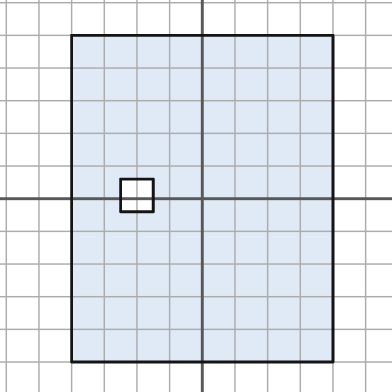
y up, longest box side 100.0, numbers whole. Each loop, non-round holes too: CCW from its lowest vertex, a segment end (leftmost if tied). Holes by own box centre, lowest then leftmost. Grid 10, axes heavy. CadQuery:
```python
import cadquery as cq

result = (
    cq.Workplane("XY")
    .moveTo(-40.0, -50.0)
    .lineTo(40.0, -50.0)
    .lineTo(40.0, 50.0)
    .lineTo(-40.0, 50.0)
    .close()
    .moveTo(-25.0, -4.0)
    .lineTo(-15.0, -4.0)
    .lineTo(-15.0, 6.0)
    .lineTo(-25.0, 6.0)
    .close()
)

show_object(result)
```